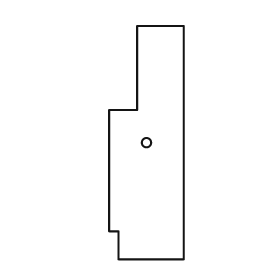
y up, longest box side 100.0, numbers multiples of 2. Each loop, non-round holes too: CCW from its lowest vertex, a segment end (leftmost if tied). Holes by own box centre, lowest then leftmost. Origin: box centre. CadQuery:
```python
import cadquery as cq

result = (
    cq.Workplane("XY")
    .moveTo(-12.0, -50.0)
    .lineTo(16.0, -50.0)
    .lineTo(16.0, 50.0)
    .lineTo(-4.0, 50.0)
    .lineTo(-4.0, 14.0)
    .lineTo(-16.0, 14.0)
    .lineTo(-16.0, -38.0)
    .lineTo(-12.0, -38.0)
    .close()
    .moveTo(0.0, 0.0)
    .circle(2.0)
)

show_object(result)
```